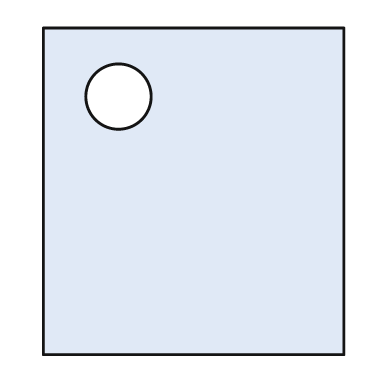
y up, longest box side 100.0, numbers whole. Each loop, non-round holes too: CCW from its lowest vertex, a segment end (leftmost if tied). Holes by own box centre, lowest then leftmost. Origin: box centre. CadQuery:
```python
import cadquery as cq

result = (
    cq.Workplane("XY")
    .moveTo(-46.0, -50.0)
    .lineTo(46.0, -50.0)
    .lineTo(46.0, 50.0)
    .lineTo(-46.0, 50.0)
    .close()
    .moveTo(-23.0, 29.0)
    .circle(10.0)
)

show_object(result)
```